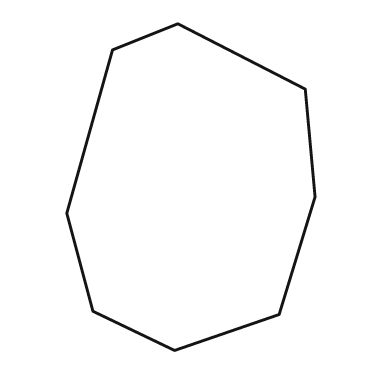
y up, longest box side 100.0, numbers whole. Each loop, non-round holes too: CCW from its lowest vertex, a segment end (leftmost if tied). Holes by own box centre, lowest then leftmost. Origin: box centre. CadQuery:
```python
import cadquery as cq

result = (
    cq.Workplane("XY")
    .moveTo(-5.0, -50.0)
    .lineTo(27.0, -39.0)
    .lineTo(38.0, -3.0)
    .lineTo(35.0, 30.0)
    .lineTo(-4.0, 50.0)
    .lineTo(-24.0, 42.0)
    .lineTo(-38.0, -8.0)
    .lineTo(-30.0, -38.0)
    .close()
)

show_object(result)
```